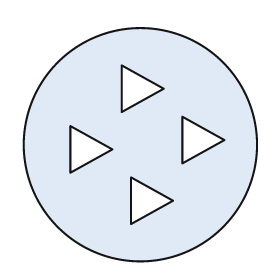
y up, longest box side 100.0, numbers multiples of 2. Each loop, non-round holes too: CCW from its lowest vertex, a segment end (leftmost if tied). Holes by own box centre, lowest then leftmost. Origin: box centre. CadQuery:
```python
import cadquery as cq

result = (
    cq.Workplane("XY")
    .moveTo(0.0, 0.0)
    .circle(50.0)
    .moveTo(-4.0, -34.0)
    .lineTo(14.0, -24.0)
    .lineTo(-4.0, -14.0)
    .close()
    .moveTo(-30.0, -12.0)
    .lineTo(-12.0, -2.0)
    .lineTo(-30.0, 8.0)
    .close()
    .moveTo(18.0, -8.0)
    .lineTo(36.0, 2.0)
    .lineTo(18.0, 12.0)
    .close()
    .moveTo(-8.0, 14.0)
    .lineTo(10.0, 24.0)
    .lineTo(-8.0, 34.0)
    .close()
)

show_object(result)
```